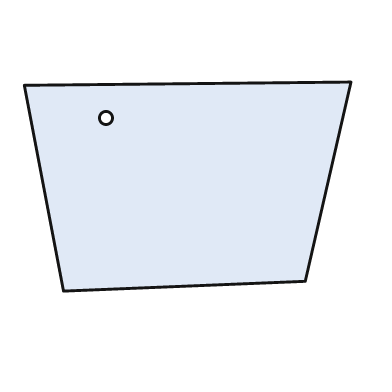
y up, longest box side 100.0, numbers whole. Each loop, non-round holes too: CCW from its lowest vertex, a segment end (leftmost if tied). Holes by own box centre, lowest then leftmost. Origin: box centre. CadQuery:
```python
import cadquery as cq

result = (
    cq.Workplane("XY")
    .moveTo(-38.0, -32.0)
    .lineTo(36.0, -29.0)
    .lineTo(50.0, 32.0)
    .lineTo(-50.0, 31.0)
    .close()
    .moveTo(-25.0, 21.0)
    .circle(2.0)
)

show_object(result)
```